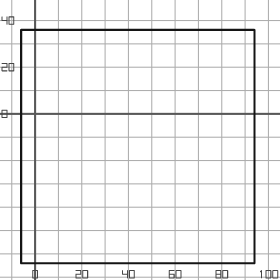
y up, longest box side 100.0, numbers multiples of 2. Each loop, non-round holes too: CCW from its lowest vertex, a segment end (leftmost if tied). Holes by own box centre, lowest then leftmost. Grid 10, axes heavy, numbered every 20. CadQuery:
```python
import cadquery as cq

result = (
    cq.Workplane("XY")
    .moveTo(-6.0, -64.0)
    .lineTo(94.0, -64.0)
    .lineTo(94.0, 36.0)
    .lineTo(-6.0, 36.0)
    .close()
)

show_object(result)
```